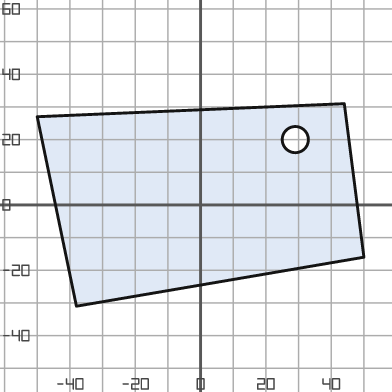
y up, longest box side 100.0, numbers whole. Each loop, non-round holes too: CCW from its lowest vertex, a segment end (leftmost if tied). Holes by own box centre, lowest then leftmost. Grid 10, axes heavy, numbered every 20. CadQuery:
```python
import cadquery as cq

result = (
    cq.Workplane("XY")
    .moveTo(-38.0, -31.0)
    .lineTo(50.0, -16.0)
    .lineTo(44.0, 31.0)
    .lineTo(-50.0, 27.0)
    .close()
    .moveTo(29.0, 20.0)
    .circle(4.0)
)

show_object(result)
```